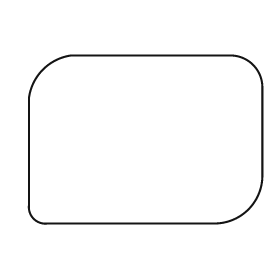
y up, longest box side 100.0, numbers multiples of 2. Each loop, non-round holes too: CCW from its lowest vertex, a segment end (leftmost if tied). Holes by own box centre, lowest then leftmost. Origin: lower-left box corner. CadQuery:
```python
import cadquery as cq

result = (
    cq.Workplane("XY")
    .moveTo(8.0, 0.0)
    .lineTo(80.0, 0.0)
    .threePointArc((94.0, 6.0), (100.0, 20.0))
    .lineTo(100.0, 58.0)
    .threePointArc((96.0, 68.0), (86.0, 72.0))
    .lineTo(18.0, 72.0)
    .threePointArc((6.0, 66.0), (0.0, 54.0))
    .lineTo(0.0, 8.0)
    .threePointArc((2.0, 2.0), (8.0, 0.0))
    .close()
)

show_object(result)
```